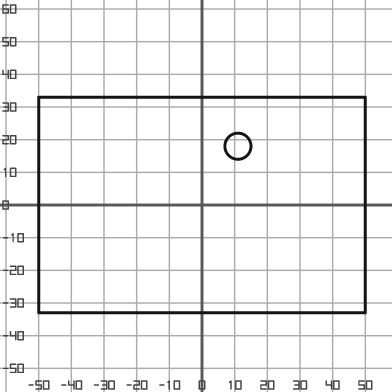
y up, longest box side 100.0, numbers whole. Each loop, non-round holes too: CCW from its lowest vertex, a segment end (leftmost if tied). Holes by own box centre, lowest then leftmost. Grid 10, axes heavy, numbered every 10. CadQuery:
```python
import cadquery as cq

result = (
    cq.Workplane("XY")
    .moveTo(-50.0, -33.0)
    .lineTo(50.0, -33.0)
    .lineTo(50.0, 33.0)
    .lineTo(-50.0, 33.0)
    .close()
    .moveTo(11.0, 18.0)
    .circle(4.0)
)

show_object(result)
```